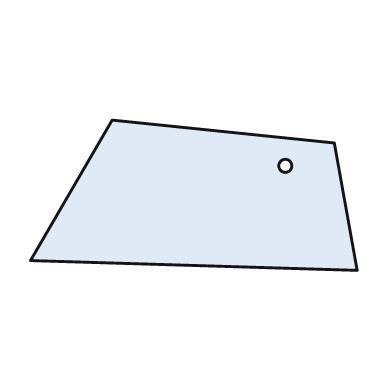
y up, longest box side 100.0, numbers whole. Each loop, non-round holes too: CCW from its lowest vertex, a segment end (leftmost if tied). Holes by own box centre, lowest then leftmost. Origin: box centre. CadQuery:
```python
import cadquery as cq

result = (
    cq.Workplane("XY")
    .moveTo(50.0, -23.0)
    .lineTo(43.0, 16.0)
    .lineTo(-25.0, 23.0)
    .lineTo(-50.0, -20.0)
    .close()
    .moveTo(28.0, 9.0)
    .circle(2.0)
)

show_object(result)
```